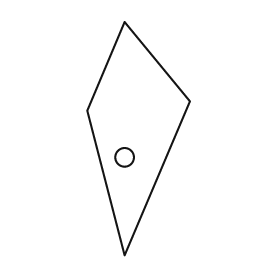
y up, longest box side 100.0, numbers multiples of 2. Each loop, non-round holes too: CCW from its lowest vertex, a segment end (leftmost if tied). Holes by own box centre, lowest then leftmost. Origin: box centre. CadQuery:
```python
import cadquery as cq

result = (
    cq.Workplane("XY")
    .moveTo(-6.0, -50.0)
    .lineTo(22.0, 16.0)
    .lineTo(-6.0, 50.0)
    .lineTo(-22.0, 12.0)
    .close()
    .moveTo(-6.0, -8.0)
    .circle(4.0)
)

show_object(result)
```